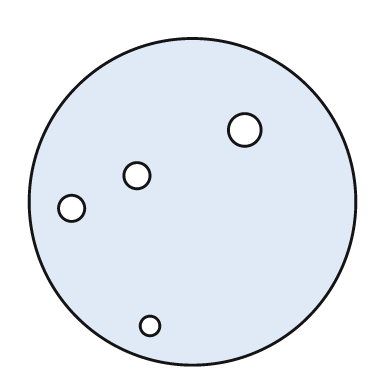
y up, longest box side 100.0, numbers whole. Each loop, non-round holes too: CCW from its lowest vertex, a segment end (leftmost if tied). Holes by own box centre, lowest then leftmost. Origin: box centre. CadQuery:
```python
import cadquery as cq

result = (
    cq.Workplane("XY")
    .moveTo(0.0, 0.0)
    .circle(50.0)
    .moveTo(-13.0, -38.0)
    .circle(3.0)
    .moveTo(-37.0, -2.0)
    .circle(4.0)
    .moveTo(-17.0, 8.0)
    .circle(4.0)
    .moveTo(16.0, 22.0)
    .circle(5.0)
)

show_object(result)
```